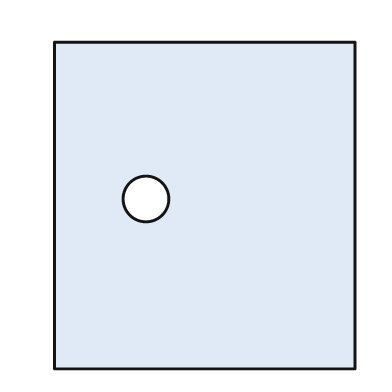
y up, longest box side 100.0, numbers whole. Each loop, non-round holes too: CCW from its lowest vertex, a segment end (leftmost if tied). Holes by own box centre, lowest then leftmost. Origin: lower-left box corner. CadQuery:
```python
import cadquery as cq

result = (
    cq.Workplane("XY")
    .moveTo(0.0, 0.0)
    .lineTo(92.0, 0.0)
    .lineTo(92.0, 100.0)
    .lineTo(0.0, 100.0)
    .close()
    .moveTo(28.0, 52.0)
    .circle(7.0)
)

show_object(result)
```